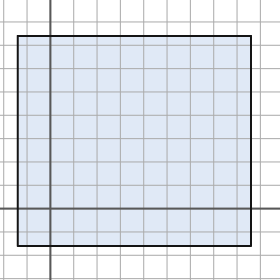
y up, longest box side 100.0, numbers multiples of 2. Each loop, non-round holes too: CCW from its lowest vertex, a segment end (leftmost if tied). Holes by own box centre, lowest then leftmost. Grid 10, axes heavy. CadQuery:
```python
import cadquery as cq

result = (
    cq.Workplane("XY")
    .moveTo(-14.0, -16.0)
    .lineTo(86.0, -16.0)
    .lineTo(86.0, 74.0)
    .lineTo(-14.0, 74.0)
    .close()
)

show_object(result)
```